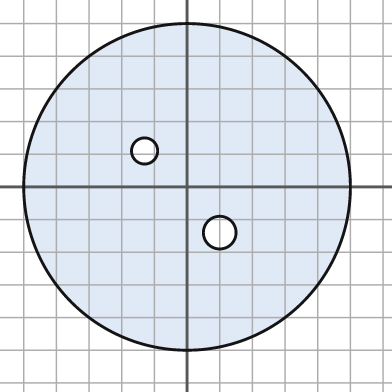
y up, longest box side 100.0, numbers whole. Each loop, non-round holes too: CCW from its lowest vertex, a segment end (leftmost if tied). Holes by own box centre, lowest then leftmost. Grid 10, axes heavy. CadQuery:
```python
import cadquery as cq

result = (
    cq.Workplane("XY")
    .moveTo(0.0, 0.0)
    .circle(50.0)
    .moveTo(10.0, -14.0)
    .circle(5.0)
    .moveTo(-13.0, 11.0)
    .circle(4.0)
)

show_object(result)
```